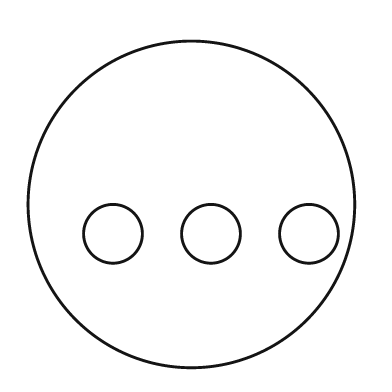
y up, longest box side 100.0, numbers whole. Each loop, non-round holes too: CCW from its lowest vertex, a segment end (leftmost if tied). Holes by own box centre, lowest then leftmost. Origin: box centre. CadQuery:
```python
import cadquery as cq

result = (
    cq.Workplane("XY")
    .moveTo(0.0, 0.0)
    .circle(50.0)
    .moveTo(-24.0, -9.0)
    .circle(9.0)
    .moveTo(6.0, -9.0)
    .circle(9.0)
    .moveTo(36.0, -9.0)
    .circle(9.0)
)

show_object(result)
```